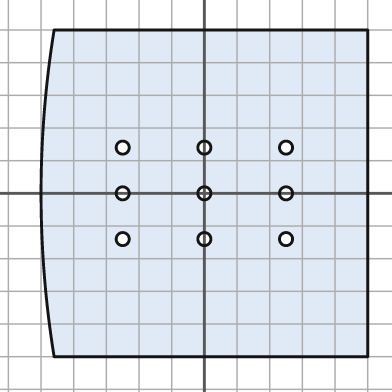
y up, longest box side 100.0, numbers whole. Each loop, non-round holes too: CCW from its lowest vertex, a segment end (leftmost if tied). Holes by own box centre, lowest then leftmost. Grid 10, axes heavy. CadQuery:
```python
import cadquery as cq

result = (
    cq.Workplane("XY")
    .moveTo(-46.0, -50.0)
    .lineTo(50.0, -50.0)
    .lineTo(50.0, 50.0)
    .lineTo(-46.0, 50.0)
    .threePointArc((-50.0, 0.0), (-46.0, -50.0))
    .close()
    .moveTo(-25.0, -14.0)
    .circle(2.0)
    .moveTo(0.0, -14.0)
    .circle(2.0)
    .moveTo(25.0, -14.0)
    .circle(2.0)
    .moveTo(-25.0, 0.0)
    .circle(2.0)
    .moveTo(0.0, 0.0)
    .circle(2.0)
    .moveTo(25.0, 0.0)
    .circle(2.0)
    .moveTo(-25.0, 14.0)
    .circle(2.0)
    .moveTo(0.0, 14.0)
    .circle(2.0)
    .moveTo(25.0, 14.0)
    .circle(2.0)
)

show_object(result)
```